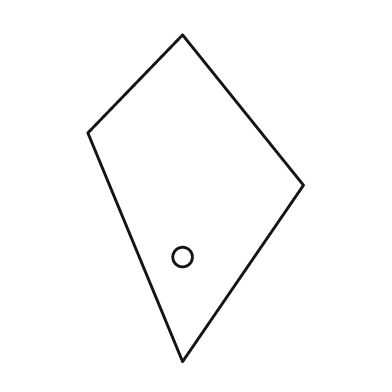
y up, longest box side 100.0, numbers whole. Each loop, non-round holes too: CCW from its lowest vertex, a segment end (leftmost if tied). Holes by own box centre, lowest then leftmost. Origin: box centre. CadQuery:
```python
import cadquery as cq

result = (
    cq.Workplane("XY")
    .moveTo(-4.0, -50.0)
    .lineTo(33.0, 4.0)
    .lineTo(-4.0, 50.0)
    .lineTo(-33.0, 20.0)
    .close()
    .moveTo(-4.0, -18.0)
    .circle(3.0)
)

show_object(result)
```